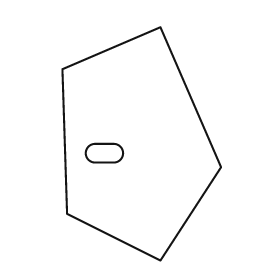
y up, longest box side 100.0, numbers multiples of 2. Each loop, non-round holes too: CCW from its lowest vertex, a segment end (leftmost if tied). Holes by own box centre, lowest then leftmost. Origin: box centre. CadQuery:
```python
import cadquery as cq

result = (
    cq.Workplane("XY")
    .moveTo(8.0, -50.0)
    .lineTo(34.0, -10.0)
    .lineTo(8.0, 50.0)
    .lineTo(-34.0, 32.0)
    .lineTo(-32.0, -30.0)
    .close()
    .moveTo(-20.0, -8.0)
    .lineTo(-12.0, -8.0)
    .threePointArc((-8.0, -4.0), (-12.0, 0.0))
    .lineTo(-20.0, 0.0)
    .threePointArc((-24.0, -4.0), (-20.0, -8.0))
    .close()
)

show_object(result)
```